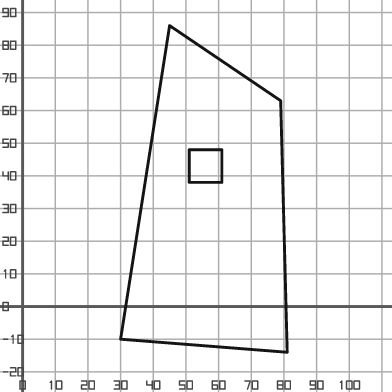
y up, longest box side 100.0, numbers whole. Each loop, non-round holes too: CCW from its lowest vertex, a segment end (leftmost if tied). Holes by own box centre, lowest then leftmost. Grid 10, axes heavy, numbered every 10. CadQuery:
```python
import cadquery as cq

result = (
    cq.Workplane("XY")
    .moveTo(81.0, -14.0)
    .lineTo(79.0, 63.0)
    .lineTo(45.0, 86.0)
    .lineTo(30.0, -10.0)
    .close()
    .moveTo(51.0, 38.0)
    .lineTo(61.0, 38.0)
    .lineTo(61.0, 48.0)
    .lineTo(51.0, 48.0)
    .close()
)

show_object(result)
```